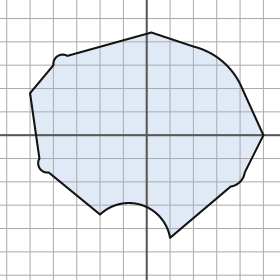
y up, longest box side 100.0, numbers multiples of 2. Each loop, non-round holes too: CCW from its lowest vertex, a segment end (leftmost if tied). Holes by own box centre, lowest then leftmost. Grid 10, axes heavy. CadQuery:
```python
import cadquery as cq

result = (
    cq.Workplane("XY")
    .moveTo(10.0, -44.0)
    .lineTo(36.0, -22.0)
    .threePointArc((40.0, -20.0), (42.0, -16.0))
    .lineTo(50.0, 0.0)
    .lineTo(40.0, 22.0)
    .threePointArc((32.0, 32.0), (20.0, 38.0))
    .lineTo(2.0, 44.0)
    .lineTo(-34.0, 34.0)
    .threePointArc((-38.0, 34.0), (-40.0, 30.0))
    .lineTo(-50.0, 18.0)
    .lineTo(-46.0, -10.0)
    .threePointArc((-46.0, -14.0), (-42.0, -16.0))
    .lineTo(-20.0, -34.0)
    .threePointArc((-2.0, -30.0), (10.0, -44.0))
    .close()
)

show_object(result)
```